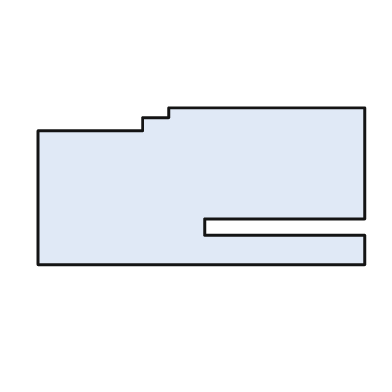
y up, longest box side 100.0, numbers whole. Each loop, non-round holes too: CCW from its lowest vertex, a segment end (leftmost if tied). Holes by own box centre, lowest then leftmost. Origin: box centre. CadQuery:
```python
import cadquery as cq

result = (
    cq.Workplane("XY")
    .moveTo(-50.0, -24.0)
    .lineTo(50.0, -24.0)
    .lineTo(50.0, -15.0)
    .lineTo(1.0, -15.0)
    .lineTo(1.0, -10.0)
    .lineTo(50.0, -10.0)
    .lineTo(50.0, 24.0)
    .lineTo(-10.0, 24.0)
    .lineTo(-10.0, 21.0)
    .lineTo(-18.0, 21.0)
    .lineTo(-18.0, 17.0)
    .lineTo(-50.0, 17.0)
    .close()
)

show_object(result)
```